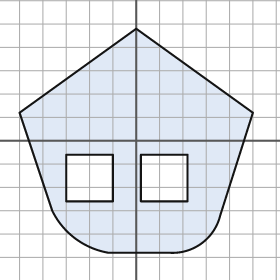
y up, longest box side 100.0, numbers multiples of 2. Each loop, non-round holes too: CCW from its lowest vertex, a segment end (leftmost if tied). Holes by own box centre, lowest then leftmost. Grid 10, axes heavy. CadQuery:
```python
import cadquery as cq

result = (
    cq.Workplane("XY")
    .moveTo(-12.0, -48.0)
    .lineTo(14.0, -48.0)
    .threePointArc((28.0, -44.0), (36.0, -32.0))
    .lineTo(50.0, 12.0)
    .lineTo(0.0, 48.0)
    .lineTo(-50.0, 12.0)
    .lineTo(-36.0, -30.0)
    .threePointArc((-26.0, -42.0), (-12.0, -48.0))
    .close()
    .moveTo(-30.0, -26.0)
    .lineTo(-10.0, -26.0)
    .lineTo(-10.0, -6.0)
    .lineTo(-30.0, -6.0)
    .close()
    .moveTo(2.0, -26.0)
    .lineTo(22.0, -26.0)
    .lineTo(22.0, -6.0)
    .lineTo(2.0, -6.0)
    .close()
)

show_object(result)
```